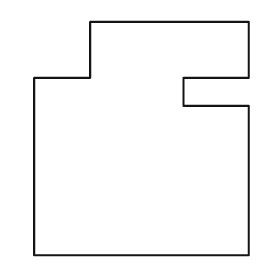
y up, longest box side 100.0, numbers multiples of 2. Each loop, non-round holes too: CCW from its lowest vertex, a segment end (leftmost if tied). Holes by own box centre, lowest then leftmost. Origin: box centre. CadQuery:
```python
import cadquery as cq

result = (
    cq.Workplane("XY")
    .moveTo(-46.0, -50.0)
    .lineTo(46.0, -50.0)
    .lineTo(46.0, 14.0)
    .lineTo(18.0, 14.0)
    .lineTo(18.0, 26.0)
    .lineTo(46.0, 26.0)
    .lineTo(46.0, 50.0)
    .lineTo(-22.0, 50.0)
    .lineTo(-22.0, 26.0)
    .lineTo(-46.0, 26.0)
    .close()
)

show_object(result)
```